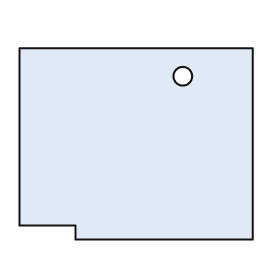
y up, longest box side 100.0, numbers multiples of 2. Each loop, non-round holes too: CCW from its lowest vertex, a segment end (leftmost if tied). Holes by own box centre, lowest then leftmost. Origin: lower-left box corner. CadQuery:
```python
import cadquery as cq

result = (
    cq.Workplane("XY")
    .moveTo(24.0, 0.0)
    .lineTo(100.0, 0.0)
    .lineTo(100.0, 82.0)
    .lineTo(0.0, 82.0)
    .lineTo(0.0, 6.0)
    .lineTo(24.0, 6.0)
    .close()
    .moveTo(70.0, 70.0)
    .circle(4.0)
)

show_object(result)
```